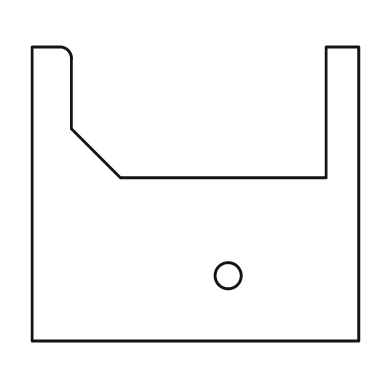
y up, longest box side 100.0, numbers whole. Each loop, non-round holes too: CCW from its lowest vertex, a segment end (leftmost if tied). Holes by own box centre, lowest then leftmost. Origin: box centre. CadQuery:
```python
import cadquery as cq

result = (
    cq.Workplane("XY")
    .moveTo(-50.0, -45.0)
    .lineTo(50.0, -45.0)
    .lineTo(50.0, 45.0)
    .lineTo(40.0, 45.0)
    .lineTo(40.0, 5.0)
    .lineTo(-23.0, 5.0)
    .lineTo(-38.0, 20.0)
    .lineTo(-38.0, 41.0)
    .threePointArc((-39.0, 44.0), (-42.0, 45.0))
    .lineTo(-50.0, 45.0)
    .close()
    .moveTo(10.0, -25.0)
    .circle(4.0)
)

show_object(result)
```